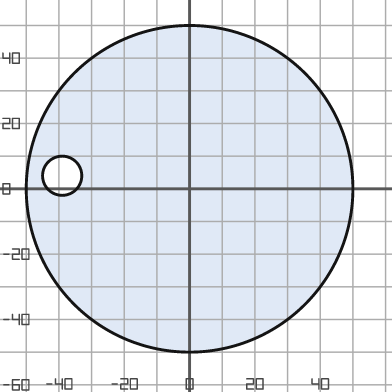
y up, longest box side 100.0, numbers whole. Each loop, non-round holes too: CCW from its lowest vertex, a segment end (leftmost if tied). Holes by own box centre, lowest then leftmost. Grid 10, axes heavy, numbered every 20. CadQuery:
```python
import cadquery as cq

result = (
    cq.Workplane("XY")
    .moveTo(0.0, 0.0)
    .circle(50.0)
    .moveTo(-39.0, 4.0)
    .circle(6.0)
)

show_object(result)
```